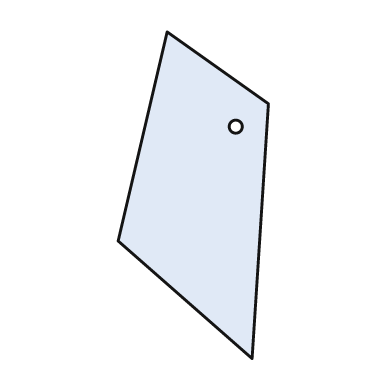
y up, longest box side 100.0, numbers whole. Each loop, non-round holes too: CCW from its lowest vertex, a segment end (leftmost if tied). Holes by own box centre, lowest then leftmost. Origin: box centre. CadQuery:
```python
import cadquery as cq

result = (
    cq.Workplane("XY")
    .moveTo(18.0, -50.0)
    .lineTo(23.0, 28.0)
    .lineTo(-8.0, 50.0)
    .lineTo(-23.0, -14.0)
    .close()
    .moveTo(13.0, 21.0)
    .circle(2.0)
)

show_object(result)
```